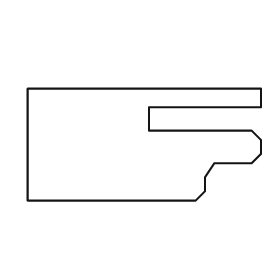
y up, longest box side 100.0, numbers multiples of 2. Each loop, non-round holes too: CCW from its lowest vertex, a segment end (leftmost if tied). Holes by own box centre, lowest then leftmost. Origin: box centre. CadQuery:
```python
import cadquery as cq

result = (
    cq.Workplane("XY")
    .moveTo(-50.0, -24.0)
    .lineTo(22.0, -24.0)
    .lineTo(26.0, -20.0)
    .lineTo(26.0, -14.0)
    .lineTo(30.0, -8.0)
    .lineTo(46.0, -8.0)
    .lineTo(50.0, -4.0)
    .lineTo(50.0, 2.0)
    .lineTo(46.0, 6.0)
    .lineTo(2.0, 6.0)
    .lineTo(2.0, 16.0)
    .lineTo(50.0, 16.0)
    .lineTo(50.0, 24.0)
    .lineTo(-50.0, 24.0)
    .close()
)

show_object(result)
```